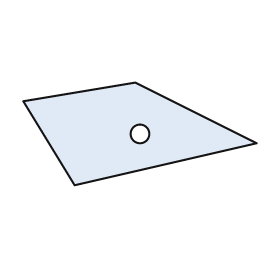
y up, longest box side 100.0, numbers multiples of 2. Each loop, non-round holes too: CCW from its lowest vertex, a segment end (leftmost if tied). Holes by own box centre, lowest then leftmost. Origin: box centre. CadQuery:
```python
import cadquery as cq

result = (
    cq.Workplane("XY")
    .moveTo(-28.0, -22.0)
    .lineTo(50.0, -4.0)
    .lineTo(-2.0, 22.0)
    .lineTo(-50.0, 14.0)
    .close()
    .moveTo(0.0, 0.0)
    .circle(4.0)
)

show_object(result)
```